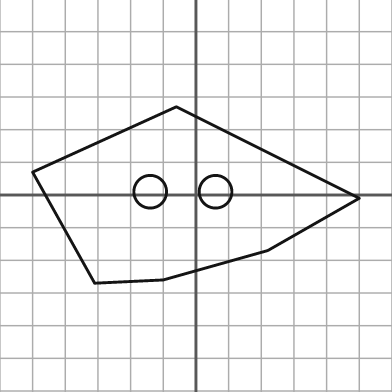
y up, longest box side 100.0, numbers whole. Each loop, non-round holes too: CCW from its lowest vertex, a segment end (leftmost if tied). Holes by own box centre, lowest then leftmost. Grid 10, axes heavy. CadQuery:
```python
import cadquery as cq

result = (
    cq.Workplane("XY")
    .moveTo(-31.0, -27.0)
    .lineTo(-10.0, -26.0)
    .lineTo(22.0, -17.0)
    .lineTo(50.0, -1.0)
    .lineTo(-6.0, 27.0)
    .lineTo(-50.0, 7.0)
    .close()
    .moveTo(-14.0, 1.0)
    .circle(5.0)
    .moveTo(6.0, 1.0)
    .circle(5.0)
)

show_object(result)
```